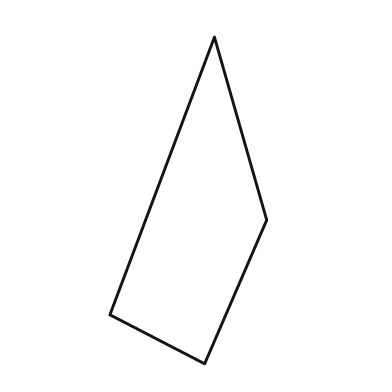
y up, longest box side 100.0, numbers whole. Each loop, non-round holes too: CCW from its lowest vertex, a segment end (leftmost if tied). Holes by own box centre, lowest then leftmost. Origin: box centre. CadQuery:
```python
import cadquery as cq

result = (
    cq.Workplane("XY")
    .moveTo(5.0, -50.0)
    .lineTo(24.0, -6.0)
    .lineTo(8.0, 50.0)
    .lineTo(-24.0, -35.0)
    .close()
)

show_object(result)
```